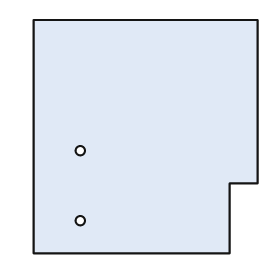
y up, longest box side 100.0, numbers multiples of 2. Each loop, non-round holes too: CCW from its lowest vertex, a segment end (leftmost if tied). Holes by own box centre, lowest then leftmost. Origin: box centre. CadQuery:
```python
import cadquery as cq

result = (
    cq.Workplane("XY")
    .moveTo(-48.0, -50.0)
    .lineTo(36.0, -50.0)
    .lineTo(36.0, -20.0)
    .lineTo(48.0, -20.0)
    .lineTo(48.0, 50.0)
    .lineTo(-48.0, 50.0)
    .close()
    .moveTo(-28.0, -36.0)
    .circle(2.0)
    .moveTo(-28.0, -6.0)
    .circle(2.0)
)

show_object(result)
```